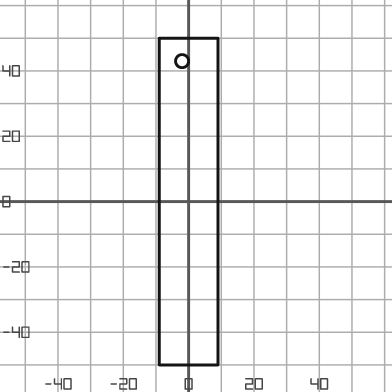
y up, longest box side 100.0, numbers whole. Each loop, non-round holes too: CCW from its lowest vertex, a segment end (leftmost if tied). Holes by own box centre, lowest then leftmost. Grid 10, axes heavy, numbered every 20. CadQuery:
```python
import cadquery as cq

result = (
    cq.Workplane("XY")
    .moveTo(-9.0, -50.0)
    .lineTo(9.0, -50.0)
    .lineTo(9.0, 50.0)
    .lineTo(-9.0, 50.0)
    .close()
    .moveTo(-2.0, 43.0)
    .circle(2.0)
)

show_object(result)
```